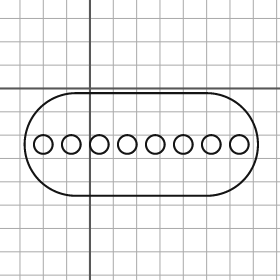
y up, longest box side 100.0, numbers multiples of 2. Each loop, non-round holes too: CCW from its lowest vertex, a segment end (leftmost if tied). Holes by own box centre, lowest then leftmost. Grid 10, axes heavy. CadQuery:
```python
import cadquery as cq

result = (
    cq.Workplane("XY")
    .moveTo(-6.0, -46.0)
    .lineTo(50.0, -46.0)
    .threePointArc((72.0, -24.0), (50.0, -2.0))
    .lineTo(-6.0, -2.0)
    .threePointArc((-28.0, -24.0), (-6.0, -46.0))
    .close()
    .moveTo(-20.0, -24.0)
    .circle(4.0)
    .moveTo(-8.0, -24.0)
    .circle(4.0)
    .moveTo(4.0, -24.0)
    .circle(4.0)
    .moveTo(16.0, -24.0)
    .circle(4.0)
    .moveTo(28.0, -24.0)
    .circle(4.0)
    .moveTo(40.0, -24.0)
    .circle(4.0)
    .moveTo(52.0, -24.0)
    .circle(4.0)
    .moveTo(64.0, -24.0)
    .circle(4.0)
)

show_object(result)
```